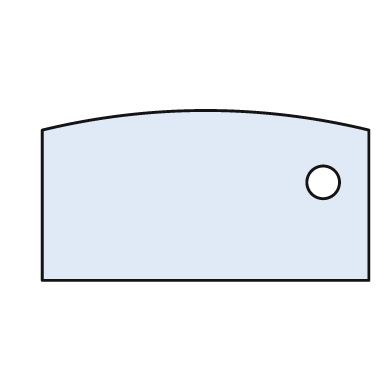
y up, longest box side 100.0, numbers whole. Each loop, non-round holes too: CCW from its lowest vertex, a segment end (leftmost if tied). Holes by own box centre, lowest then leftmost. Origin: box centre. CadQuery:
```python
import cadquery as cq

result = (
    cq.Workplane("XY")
    .moveTo(-50.0, -26.0)
    .lineTo(50.0, -26.0)
    .lineTo(50.0, 20.0)
    .threePointArc((0.0, 26.0), (-50.0, 20.0))
    .close()
    .moveTo(36.0, 4.0)
    .circle(5.0)
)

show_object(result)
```